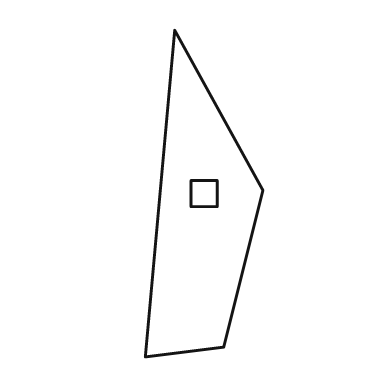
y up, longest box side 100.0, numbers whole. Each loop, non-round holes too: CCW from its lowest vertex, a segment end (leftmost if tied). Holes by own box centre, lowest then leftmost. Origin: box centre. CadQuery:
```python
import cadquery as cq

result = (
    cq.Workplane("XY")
    .moveTo(-18.0, -50.0)
    .lineTo(6.0, -47.0)
    .lineTo(18.0, 1.0)
    .lineTo(-9.0, 50.0)
    .close()
    .moveTo(-4.0, -4.0)
    .lineTo(4.0, -4.0)
    .lineTo(4.0, 4.0)
    .lineTo(-4.0, 4.0)
    .close()
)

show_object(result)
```